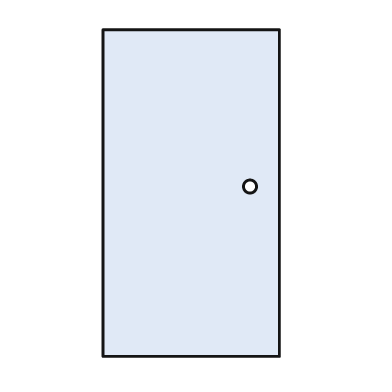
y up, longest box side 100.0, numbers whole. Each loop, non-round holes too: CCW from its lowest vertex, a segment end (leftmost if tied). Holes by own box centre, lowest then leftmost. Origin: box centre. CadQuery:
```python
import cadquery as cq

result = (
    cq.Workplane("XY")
    .moveTo(-27.0, -50.0)
    .lineTo(27.0, -50.0)
    .lineTo(27.0, 50.0)
    .lineTo(-27.0, 50.0)
    .close()
    .moveTo(18.0, 2.0)
    .circle(2.0)
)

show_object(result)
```